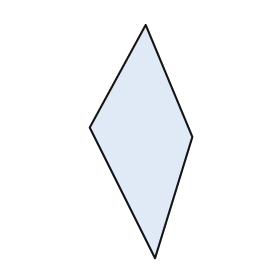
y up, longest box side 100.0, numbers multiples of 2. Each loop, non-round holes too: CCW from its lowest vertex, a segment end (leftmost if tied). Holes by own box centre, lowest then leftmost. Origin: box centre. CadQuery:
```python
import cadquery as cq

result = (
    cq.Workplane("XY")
    .moveTo(6.0, -50.0)
    .lineTo(22.0, 2.0)
    .lineTo(2.0, 50.0)
    .lineTo(-22.0, 6.0)
    .close()
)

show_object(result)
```